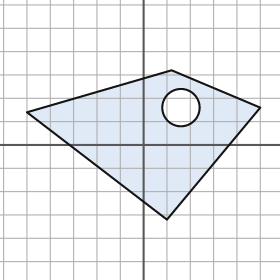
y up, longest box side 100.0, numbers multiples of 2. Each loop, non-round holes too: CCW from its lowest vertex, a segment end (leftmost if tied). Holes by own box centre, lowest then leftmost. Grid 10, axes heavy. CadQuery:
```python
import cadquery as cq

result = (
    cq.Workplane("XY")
    .moveTo(10.0, -32.0)
    .lineTo(50.0, 16.0)
    .lineTo(12.0, 32.0)
    .lineTo(-50.0, 14.0)
    .close()
    .moveTo(16.0, 16.0)
    .circle(8.0)
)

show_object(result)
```